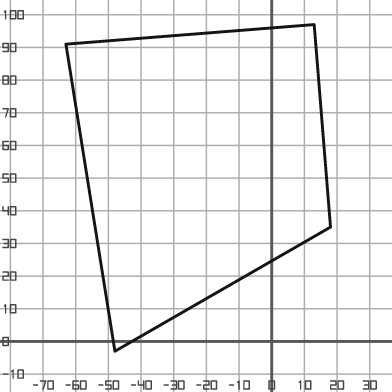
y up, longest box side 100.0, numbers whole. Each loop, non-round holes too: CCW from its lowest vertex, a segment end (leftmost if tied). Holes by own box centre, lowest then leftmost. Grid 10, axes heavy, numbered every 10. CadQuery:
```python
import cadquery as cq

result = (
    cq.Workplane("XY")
    .moveTo(-48.0, -3.0)
    .lineTo(18.0, 35.0)
    .lineTo(13.0, 97.0)
    .lineTo(-63.0, 91.0)
    .close()
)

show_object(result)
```